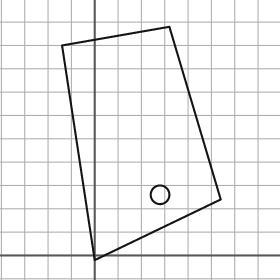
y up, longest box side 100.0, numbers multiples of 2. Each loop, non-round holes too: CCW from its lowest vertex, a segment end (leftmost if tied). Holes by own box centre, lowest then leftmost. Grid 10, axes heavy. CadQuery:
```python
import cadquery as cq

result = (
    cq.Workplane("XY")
    .moveTo(0.0, -2.0)
    .lineTo(54.0, 24.0)
    .lineTo(32.0, 98.0)
    .lineTo(-14.0, 90.0)
    .close()
    .moveTo(28.0, 26.0)
    .circle(4.0)
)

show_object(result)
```